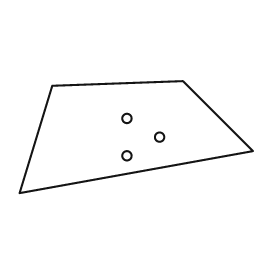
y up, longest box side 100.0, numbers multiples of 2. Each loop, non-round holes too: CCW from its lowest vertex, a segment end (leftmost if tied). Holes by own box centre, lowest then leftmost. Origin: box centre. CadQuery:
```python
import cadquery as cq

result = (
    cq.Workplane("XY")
    .moveTo(-50.0, -24.0)
    .lineTo(50.0, -6.0)
    .lineTo(20.0, 24.0)
    .lineTo(-36.0, 22.0)
    .close()
    .moveTo(-4.0, -8.0)
    .circle(2.0)
    .moveTo(10.0, 0.0)
    .circle(2.0)
    .moveTo(-4.0, 8.0)
    .circle(2.0)
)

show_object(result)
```